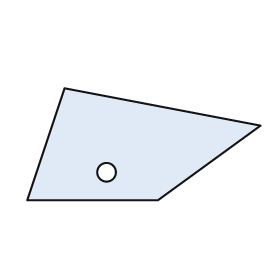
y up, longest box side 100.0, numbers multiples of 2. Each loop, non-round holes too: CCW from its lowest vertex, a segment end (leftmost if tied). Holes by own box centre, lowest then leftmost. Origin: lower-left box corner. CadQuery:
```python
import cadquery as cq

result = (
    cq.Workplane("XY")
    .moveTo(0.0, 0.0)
    .lineTo(56.0, 0.0)
    .lineTo(100.0, 32.0)
    .lineTo(16.0, 48.0)
    .close()
    .moveTo(34.0, 12.0)
    .circle(4.0)
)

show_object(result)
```